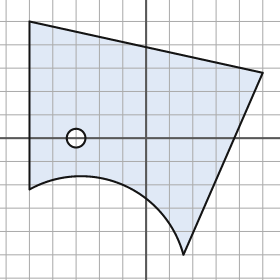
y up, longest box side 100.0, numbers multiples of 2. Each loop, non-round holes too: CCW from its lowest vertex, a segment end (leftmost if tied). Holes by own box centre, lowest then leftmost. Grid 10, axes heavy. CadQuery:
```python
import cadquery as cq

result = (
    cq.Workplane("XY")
    .moveTo(16.0, -50.0)
    .lineTo(50.0, 28.0)
    .lineTo(-50.0, 50.0)
    .lineTo(-50.0, -22.0)
    .threePointArc((-10.0, -20.0), (16.0, -50.0))
    .close()
    .moveTo(-30.0, 0.0)
    .circle(4.0)
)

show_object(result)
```